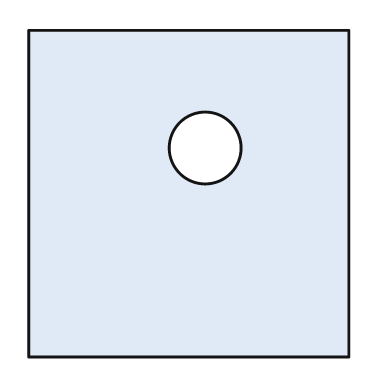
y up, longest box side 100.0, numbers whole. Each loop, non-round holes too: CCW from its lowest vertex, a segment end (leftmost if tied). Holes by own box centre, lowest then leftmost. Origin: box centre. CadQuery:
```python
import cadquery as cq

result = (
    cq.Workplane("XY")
    .moveTo(-49.0, -50.0)
    .lineTo(49.0, -50.0)
    .lineTo(49.0, 50.0)
    .lineTo(-49.0, 50.0)
    .close()
    .moveTo(5.0, 14.0)
    .circle(11.0)
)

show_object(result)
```